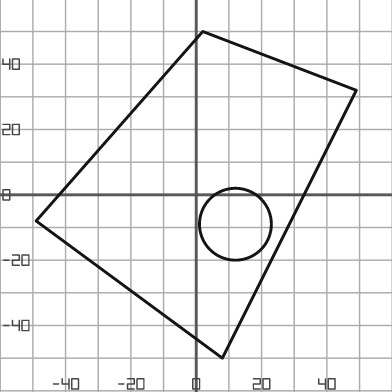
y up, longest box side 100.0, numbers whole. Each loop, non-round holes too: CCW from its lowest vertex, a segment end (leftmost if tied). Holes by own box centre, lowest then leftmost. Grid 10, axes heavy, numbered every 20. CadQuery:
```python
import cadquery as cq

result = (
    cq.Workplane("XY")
    .moveTo(8.0, -50.0)
    .lineTo(49.0, 32.0)
    .lineTo(2.0, 50.0)
    .lineTo(-49.0, -8.0)
    .close()
    .moveTo(12.0, -9.0)
    .circle(11.0)
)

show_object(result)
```